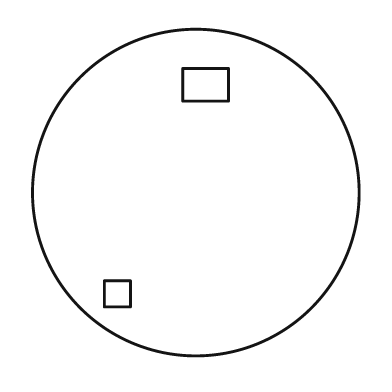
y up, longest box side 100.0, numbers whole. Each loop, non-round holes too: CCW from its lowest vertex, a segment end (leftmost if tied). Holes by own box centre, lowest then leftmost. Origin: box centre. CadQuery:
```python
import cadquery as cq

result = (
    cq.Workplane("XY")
    .moveTo(0.0, 0.0)
    .circle(50.0)
    .moveTo(-28.0, -35.0)
    .lineTo(-20.0, -35.0)
    .lineTo(-20.0, -27.0)
    .lineTo(-28.0, -27.0)
    .close()
    .moveTo(-4.0, 28.0)
    .lineTo(10.0, 28.0)
    .lineTo(10.0, 38.0)
    .lineTo(-4.0, 38.0)
    .close()
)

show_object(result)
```